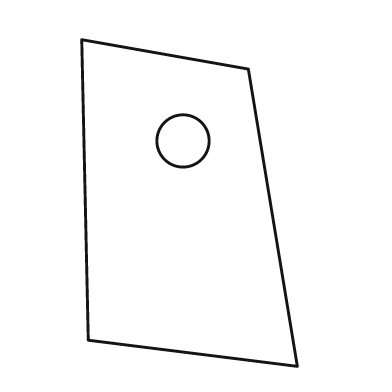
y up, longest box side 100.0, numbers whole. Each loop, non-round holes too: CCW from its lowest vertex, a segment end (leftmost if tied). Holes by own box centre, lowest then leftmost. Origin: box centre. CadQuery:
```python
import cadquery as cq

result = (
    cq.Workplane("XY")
    .moveTo(33.0, -50.0)
    .lineTo(18.0, 41.0)
    .lineTo(-33.0, 50.0)
    .lineTo(-31.0, -42.0)
    .close()
    .moveTo(-2.0, 19.0)
    .circle(8.0)
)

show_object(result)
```